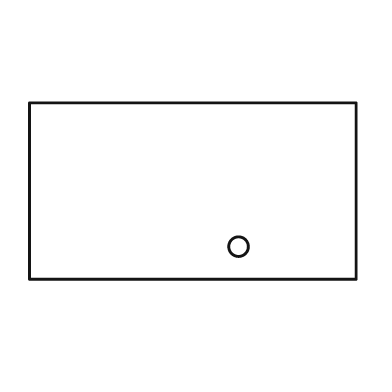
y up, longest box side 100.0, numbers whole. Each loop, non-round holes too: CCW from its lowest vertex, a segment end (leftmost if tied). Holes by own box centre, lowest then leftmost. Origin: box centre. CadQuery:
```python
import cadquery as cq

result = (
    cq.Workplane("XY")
    .moveTo(-50.0, -27.0)
    .lineTo(50.0, -27.0)
    .lineTo(50.0, 27.0)
    .lineTo(-50.0, 27.0)
    .close()
    .moveTo(14.0, -17.0)
    .circle(3.0)
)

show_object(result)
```